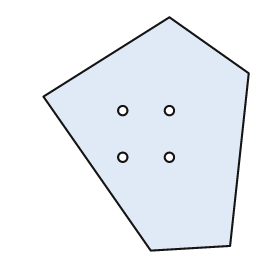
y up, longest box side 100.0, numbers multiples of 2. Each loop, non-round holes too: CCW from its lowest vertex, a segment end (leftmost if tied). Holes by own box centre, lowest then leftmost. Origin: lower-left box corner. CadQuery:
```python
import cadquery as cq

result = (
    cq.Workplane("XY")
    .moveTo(46.0, 0.0)
    .lineTo(80.0, 2.0)
    .lineTo(88.0, 76.0)
    .lineTo(54.0, 100.0)
    .lineTo(0.0, 66.0)
    .close()
    .moveTo(34.0, 40.0)
    .circle(2.0)
    .moveTo(54.0, 40.0)
    .circle(2.0)
    .moveTo(34.0, 60.0)
    .circle(2.0)
    .moveTo(54.0, 60.0)
    .circle(2.0)
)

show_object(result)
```